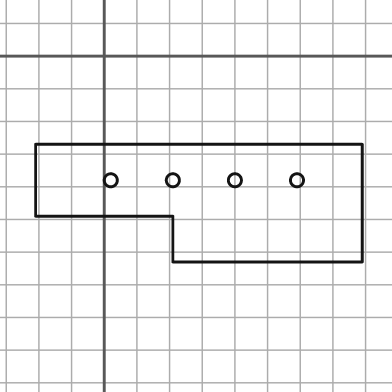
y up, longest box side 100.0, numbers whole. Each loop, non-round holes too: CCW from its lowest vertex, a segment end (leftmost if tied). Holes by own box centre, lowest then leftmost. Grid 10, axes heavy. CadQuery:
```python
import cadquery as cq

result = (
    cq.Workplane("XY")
    .moveTo(21.0, -63.0)
    .lineTo(79.0, -63.0)
    .lineTo(79.0, -27.0)
    .lineTo(-21.0, -27.0)
    .lineTo(-21.0, -49.0)
    .lineTo(21.0, -49.0)
    .close()
    .moveTo(2.0, -38.0)
    .circle(2.0)
    .moveTo(21.0, -38.0)
    .circle(2.0)
    .moveTo(40.0, -38.0)
    .circle(2.0)
    .moveTo(59.0, -38.0)
    .circle(2.0)
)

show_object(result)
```